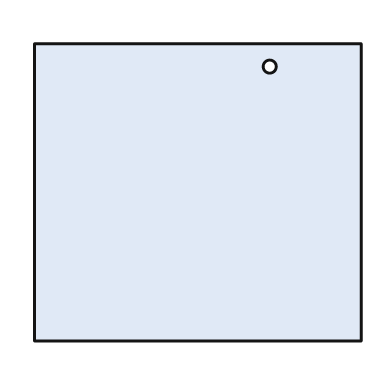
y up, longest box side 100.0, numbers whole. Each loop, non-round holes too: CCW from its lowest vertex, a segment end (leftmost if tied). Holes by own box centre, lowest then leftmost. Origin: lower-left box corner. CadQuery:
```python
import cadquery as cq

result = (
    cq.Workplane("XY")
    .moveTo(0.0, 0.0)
    .lineTo(100.0, 0.0)
    .lineTo(100.0, 91.0)
    .lineTo(0.0, 91.0)
    .close()
    .moveTo(72.0, 84.0)
    .circle(2.0)
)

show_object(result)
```